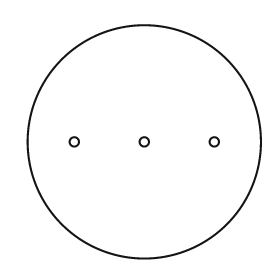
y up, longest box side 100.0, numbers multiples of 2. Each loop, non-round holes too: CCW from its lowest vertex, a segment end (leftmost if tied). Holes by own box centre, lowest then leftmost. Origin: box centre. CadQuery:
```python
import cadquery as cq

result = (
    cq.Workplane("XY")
    .moveTo(0.0, 0.0)
    .circle(50.0)
    .moveTo(-30.0, 0.0)
    .circle(2.0)
    .moveTo(0.0, 0.0)
    .circle(2.0)
    .moveTo(30.0, 0.0)
    .circle(2.0)
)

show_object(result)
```